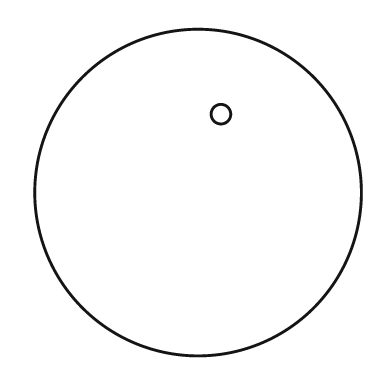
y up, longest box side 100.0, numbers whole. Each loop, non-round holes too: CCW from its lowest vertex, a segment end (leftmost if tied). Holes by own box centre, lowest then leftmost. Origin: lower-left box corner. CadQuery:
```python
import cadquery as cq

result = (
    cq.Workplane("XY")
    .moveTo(50.0, 50.0)
    .circle(50.0)
    .moveTo(57.0, 74.0)
    .circle(3.0)
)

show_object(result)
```